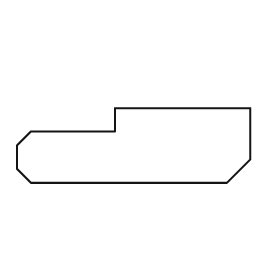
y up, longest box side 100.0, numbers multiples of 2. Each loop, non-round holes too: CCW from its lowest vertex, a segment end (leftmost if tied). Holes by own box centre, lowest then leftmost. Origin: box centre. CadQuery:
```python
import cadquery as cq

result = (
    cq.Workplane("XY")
    .moveTo(-44.0, -16.0)
    .lineTo(40.0, -16.0)
    .lineTo(50.0, -6.0)
    .lineTo(50.0, 16.0)
    .lineTo(-8.0, 16.0)
    .lineTo(-8.0, 6.0)
    .lineTo(-44.0, 6.0)
    .lineTo(-50.0, 0.0)
    .lineTo(-50.0, -10.0)
    .close()
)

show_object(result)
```